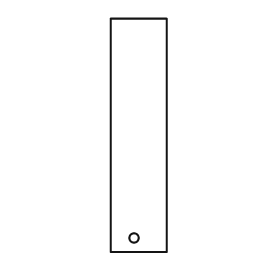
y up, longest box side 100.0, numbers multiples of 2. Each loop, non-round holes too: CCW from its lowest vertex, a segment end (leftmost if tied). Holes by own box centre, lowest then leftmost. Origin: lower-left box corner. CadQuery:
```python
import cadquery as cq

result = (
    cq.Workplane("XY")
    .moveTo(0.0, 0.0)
    .lineTo(24.0, 0.0)
    .lineTo(24.0, 100.0)
    .lineTo(0.0, 100.0)
    .close()
    .moveTo(10.0, 6.0)
    .circle(2.0)
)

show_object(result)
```